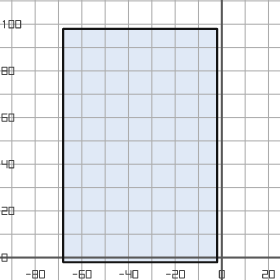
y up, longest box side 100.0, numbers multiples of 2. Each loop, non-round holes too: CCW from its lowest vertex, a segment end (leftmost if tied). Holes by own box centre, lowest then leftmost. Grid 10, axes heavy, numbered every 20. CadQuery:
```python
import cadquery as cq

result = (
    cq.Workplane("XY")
    .moveTo(-68.0, -2.0)
    .lineTo(-2.0, -2.0)
    .lineTo(-2.0, 98.0)
    .lineTo(-68.0, 98.0)
    .close()
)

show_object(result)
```